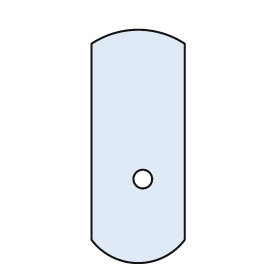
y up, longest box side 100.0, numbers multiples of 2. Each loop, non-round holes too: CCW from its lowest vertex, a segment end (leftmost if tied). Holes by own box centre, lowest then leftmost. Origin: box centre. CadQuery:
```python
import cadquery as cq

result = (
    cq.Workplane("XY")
    .moveTo(-20.0, -40.0)
    .threePointArc((0.0, -50.0), (20.0, -40.0))
    .lineTo(20.0, 44.0)
    .threePointArc((0.0, 50.0), (-20.0, 44.0))
    .close()
    .moveTo(2.0, -14.0)
    .circle(4.0)
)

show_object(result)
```